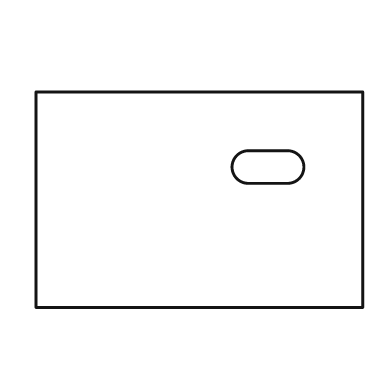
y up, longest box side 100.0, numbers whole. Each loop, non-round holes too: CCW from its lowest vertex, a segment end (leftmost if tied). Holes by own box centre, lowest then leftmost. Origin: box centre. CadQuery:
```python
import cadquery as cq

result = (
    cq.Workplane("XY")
    .moveTo(-50.0, -33.0)
    .lineTo(50.0, -33.0)
    .lineTo(50.0, 33.0)
    .lineTo(-50.0, 33.0)
    .close()
    .moveTo(15.0, 5.0)
    .lineTo(27.0, 5.0)
    .threePointArc((32.0, 10.0), (27.0, 15.0))
    .lineTo(15.0, 15.0)
    .threePointArc((10.0, 10.0), (15.0, 5.0))
    .close()
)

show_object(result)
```